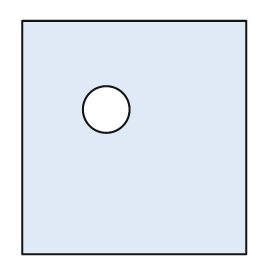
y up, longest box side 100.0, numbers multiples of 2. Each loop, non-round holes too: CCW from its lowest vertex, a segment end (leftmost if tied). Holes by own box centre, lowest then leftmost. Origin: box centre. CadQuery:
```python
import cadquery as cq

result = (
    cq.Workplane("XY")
    .moveTo(-48.0, -50.0)
    .lineTo(48.0, -50.0)
    .lineTo(48.0, 50.0)
    .lineTo(-48.0, 50.0)
    .close()
    .moveTo(-12.0, 12.0)
    .circle(10.0)
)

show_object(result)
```